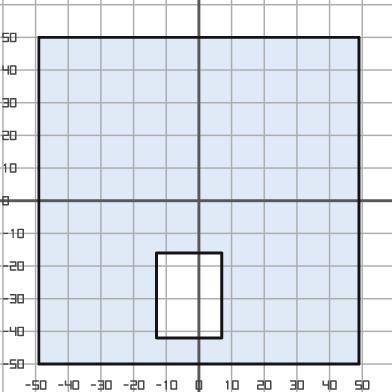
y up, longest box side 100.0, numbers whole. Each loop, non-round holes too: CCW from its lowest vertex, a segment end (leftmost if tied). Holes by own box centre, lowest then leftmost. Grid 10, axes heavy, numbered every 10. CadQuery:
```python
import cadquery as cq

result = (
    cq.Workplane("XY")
    .moveTo(-49.0, -50.0)
    .lineTo(49.0, -50.0)
    .lineTo(49.0, 50.0)
    .lineTo(-49.0, 50.0)
    .close()
    .moveTo(-13.0, -42.0)
    .lineTo(7.0, -42.0)
    .lineTo(7.0, -16.0)
    .lineTo(-13.0, -16.0)
    .close()
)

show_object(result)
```